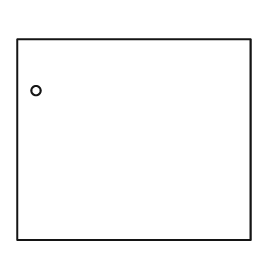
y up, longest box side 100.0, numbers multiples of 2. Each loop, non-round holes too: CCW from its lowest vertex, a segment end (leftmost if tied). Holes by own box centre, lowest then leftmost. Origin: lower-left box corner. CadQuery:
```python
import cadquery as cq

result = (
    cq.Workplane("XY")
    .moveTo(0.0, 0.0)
    .lineTo(100.0, 0.0)
    .lineTo(100.0, 86.0)
    .lineTo(0.0, 86.0)
    .close()
    .moveTo(8.0, 64.0)
    .circle(2.0)
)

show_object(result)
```